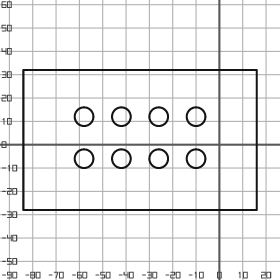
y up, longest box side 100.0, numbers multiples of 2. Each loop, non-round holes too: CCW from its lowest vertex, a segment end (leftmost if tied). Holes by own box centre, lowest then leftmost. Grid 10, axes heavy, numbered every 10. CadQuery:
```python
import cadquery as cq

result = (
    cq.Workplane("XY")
    .moveTo(-84.0, -28.0)
    .lineTo(16.0, -28.0)
    .lineTo(16.0, 32.0)
    .lineTo(-84.0, 32.0)
    .close()
    .moveTo(-58.0, -6.0)
    .circle(4.0)
    .moveTo(-42.0, -6.0)
    .circle(4.0)
    .moveTo(-26.0, -6.0)
    .circle(4.0)
    .moveTo(-10.0, -6.0)
    .circle(4.0)
    .moveTo(-58.0, 12.0)
    .circle(4.0)
    .moveTo(-42.0, 12.0)
    .circle(4.0)
    .moveTo(-26.0, 12.0)
    .circle(4.0)
    .moveTo(-10.0, 12.0)
    .circle(4.0)
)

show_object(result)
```